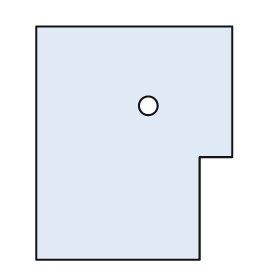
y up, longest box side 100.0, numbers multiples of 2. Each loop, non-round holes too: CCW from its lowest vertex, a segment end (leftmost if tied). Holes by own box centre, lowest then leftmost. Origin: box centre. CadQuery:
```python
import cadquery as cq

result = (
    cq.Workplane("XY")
    .moveTo(-42.0, -50.0)
    .lineTo(28.0, -50.0)
    .lineTo(28.0, -6.0)
    .lineTo(42.0, -6.0)
    .lineTo(42.0, 50.0)
    .lineTo(-42.0, 50.0)
    .close()
    .moveTo(6.0, 16.0)
    .circle(4.0)
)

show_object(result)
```